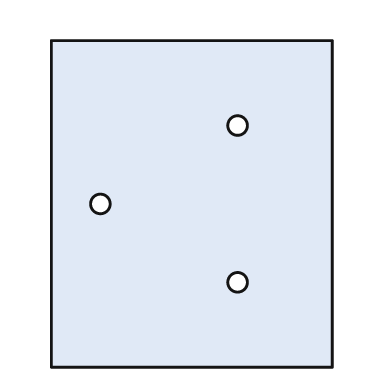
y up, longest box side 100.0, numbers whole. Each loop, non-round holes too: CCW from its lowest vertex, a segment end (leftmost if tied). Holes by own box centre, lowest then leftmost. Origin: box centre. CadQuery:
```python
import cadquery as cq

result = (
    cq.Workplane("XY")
    .moveTo(-43.0, -50.0)
    .lineTo(43.0, -50.0)
    .lineTo(43.0, 50.0)
    .lineTo(-43.0, 50.0)
    .close()
    .moveTo(14.0, -24.0)
    .circle(3.0)
    .moveTo(-28.0, 0.0)
    .circle(3.0)
    .moveTo(14.0, 24.0)
    .circle(3.0)
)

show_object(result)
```